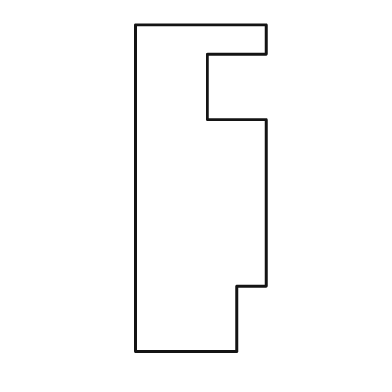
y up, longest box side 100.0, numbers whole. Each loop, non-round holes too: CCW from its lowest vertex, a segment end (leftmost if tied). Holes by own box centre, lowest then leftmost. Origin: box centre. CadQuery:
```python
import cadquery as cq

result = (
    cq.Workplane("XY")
    .moveTo(-20.0, -50.0)
    .lineTo(11.0, -50.0)
    .lineTo(11.0, -30.0)
    .lineTo(20.0, -30.0)
    .lineTo(20.0, 21.0)
    .lineTo(2.0, 21.0)
    .lineTo(2.0, 41.0)
    .lineTo(20.0, 41.0)
    .lineTo(20.0, 50.0)
    .lineTo(-20.0, 50.0)
    .close()
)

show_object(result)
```